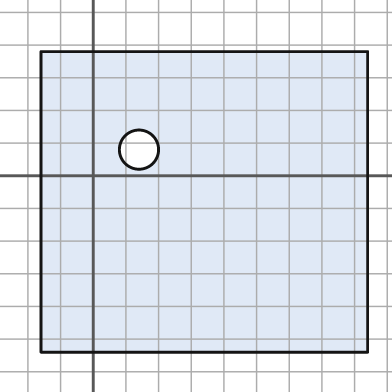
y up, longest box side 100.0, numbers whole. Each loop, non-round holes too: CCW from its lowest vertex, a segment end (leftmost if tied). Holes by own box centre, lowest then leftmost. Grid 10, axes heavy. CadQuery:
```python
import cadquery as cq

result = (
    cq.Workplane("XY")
    .moveTo(-16.0, -54.0)
    .lineTo(84.0, -54.0)
    .lineTo(84.0, 38.0)
    .lineTo(-16.0, 38.0)
    .close()
    .moveTo(14.0, 8.0)
    .circle(6.0)
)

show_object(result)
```